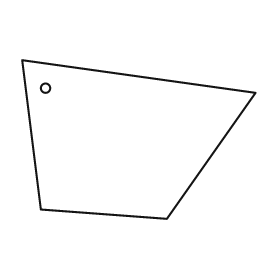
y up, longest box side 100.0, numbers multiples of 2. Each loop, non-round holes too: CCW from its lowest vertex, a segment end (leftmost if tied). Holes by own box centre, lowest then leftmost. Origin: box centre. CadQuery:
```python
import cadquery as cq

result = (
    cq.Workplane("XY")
    .moveTo(12.0, -34.0)
    .lineTo(50.0, 20.0)
    .lineTo(-50.0, 34.0)
    .lineTo(-42.0, -30.0)
    .close()
    .moveTo(-40.0, 22.0)
    .circle(2.0)
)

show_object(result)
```